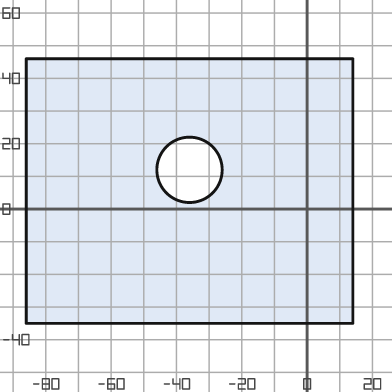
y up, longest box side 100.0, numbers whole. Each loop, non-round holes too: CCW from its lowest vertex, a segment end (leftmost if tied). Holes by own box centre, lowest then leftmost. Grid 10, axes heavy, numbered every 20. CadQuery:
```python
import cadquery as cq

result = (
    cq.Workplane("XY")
    .moveTo(-86.0, -35.0)
    .lineTo(14.0, -35.0)
    .lineTo(14.0, 46.0)
    .lineTo(-86.0, 46.0)
    .close()
    .moveTo(-36.0, 12.0)
    .circle(10.0)
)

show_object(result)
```